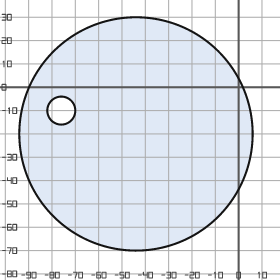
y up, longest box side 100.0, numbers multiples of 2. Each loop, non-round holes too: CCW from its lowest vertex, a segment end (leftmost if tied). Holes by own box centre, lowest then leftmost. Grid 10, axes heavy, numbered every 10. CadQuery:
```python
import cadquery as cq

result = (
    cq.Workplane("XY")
    .moveTo(-44.0, -20.0)
    .circle(50.0)
    .moveTo(-76.0, -10.0)
    .circle(6.0)
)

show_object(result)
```